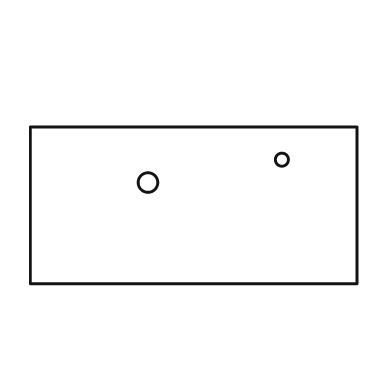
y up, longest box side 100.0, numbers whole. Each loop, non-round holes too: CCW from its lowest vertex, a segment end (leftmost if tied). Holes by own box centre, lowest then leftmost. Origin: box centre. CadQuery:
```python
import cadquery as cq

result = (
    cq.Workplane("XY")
    .moveTo(-50.0, -24.0)
    .lineTo(50.0, -24.0)
    .lineTo(50.0, 24.0)
    .lineTo(-50.0, 24.0)
    .close()
    .moveTo(-14.0, 7.0)
    .circle(3.0)
    .moveTo(27.0, 14.0)
    .circle(2.0)
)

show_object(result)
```